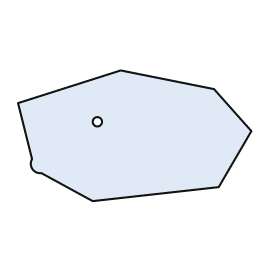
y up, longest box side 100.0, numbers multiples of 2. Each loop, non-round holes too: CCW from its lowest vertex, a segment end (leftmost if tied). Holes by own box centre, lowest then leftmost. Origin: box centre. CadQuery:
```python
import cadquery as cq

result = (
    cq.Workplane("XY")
    .moveTo(-18.0, -28.0)
    .lineTo(36.0, -22.0)
    .lineTo(50.0, 2.0)
    .lineTo(34.0, 20.0)
    .lineTo(-6.0, 28.0)
    .lineTo(-50.0, 14.0)
    .lineTo(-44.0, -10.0)
    .threePointArc((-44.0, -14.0), (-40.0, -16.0))
    .close()
    .moveTo(-16.0, 6.0)
    .circle(2.0)
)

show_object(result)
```